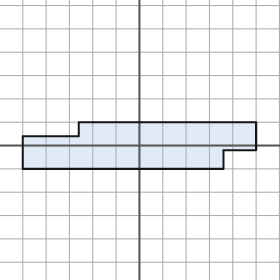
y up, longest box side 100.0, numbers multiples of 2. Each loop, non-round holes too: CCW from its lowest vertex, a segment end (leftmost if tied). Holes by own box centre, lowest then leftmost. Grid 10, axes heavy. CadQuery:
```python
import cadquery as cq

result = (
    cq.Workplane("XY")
    .moveTo(-50.0, -10.0)
    .lineTo(36.0, -10.0)
    .lineTo(36.0, -2.0)
    .lineTo(50.0, -2.0)
    .lineTo(50.0, 10.0)
    .lineTo(-26.0, 10.0)
    .lineTo(-26.0, 4.0)
    .lineTo(-50.0, 4.0)
    .close()
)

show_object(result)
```